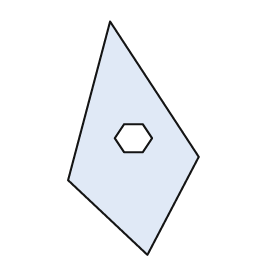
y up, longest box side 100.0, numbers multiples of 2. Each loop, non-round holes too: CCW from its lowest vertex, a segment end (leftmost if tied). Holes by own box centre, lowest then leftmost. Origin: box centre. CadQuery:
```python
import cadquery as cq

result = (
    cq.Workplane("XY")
    .moveTo(6.0, -50.0)
    .lineTo(28.0, -8.0)
    .lineTo(-10.0, 50.0)
    .lineTo(-28.0, -18.0)
    .close()
    .moveTo(-4.0, -6.0)
    .lineTo(4.0, -6.0)
    .lineTo(8.0, 0.0)
    .lineTo(4.0, 6.0)
    .lineTo(-4.0, 6.0)
    .lineTo(-8.0, 0.0)
    .close()
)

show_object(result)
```